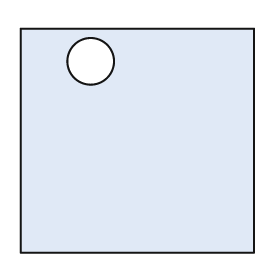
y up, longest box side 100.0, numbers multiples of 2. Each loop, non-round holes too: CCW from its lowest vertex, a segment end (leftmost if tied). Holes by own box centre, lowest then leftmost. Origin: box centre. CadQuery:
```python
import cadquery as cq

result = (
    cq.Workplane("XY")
    .moveTo(-50.0, -48.0)
    .lineTo(50.0, -48.0)
    .lineTo(50.0, 48.0)
    .lineTo(-50.0, 48.0)
    .close()
    .moveTo(-20.0, 34.0)
    .circle(10.0)
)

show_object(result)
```